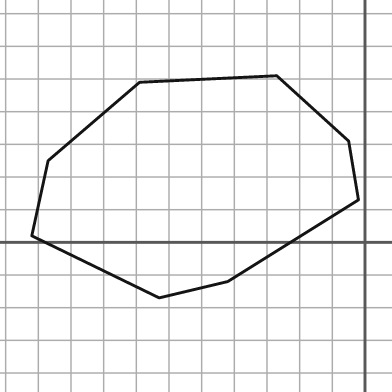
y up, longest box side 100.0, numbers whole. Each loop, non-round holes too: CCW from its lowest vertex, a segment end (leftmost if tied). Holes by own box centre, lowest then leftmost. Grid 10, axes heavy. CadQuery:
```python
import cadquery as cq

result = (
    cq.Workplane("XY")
    .moveTo(-63.0, -17.0)
    .lineTo(-42.0, -12.0)
    .lineTo(-2.0, 13.0)
    .lineTo(-5.0, 31.0)
    .lineTo(-27.0, 51.0)
    .lineTo(-69.0, 49.0)
    .lineTo(-97.0, 25.0)
    .lineTo(-102.0, 2.0)
    .close()
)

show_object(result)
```